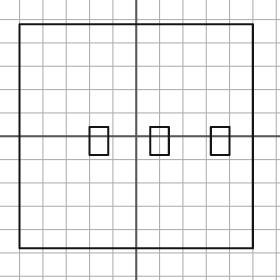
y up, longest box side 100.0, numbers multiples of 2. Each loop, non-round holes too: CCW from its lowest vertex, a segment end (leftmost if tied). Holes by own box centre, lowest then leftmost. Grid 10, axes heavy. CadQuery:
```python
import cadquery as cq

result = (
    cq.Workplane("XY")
    .moveTo(-50.0, -48.0)
    .lineTo(50.0, -48.0)
    .lineTo(50.0, 48.0)
    .lineTo(-50.0, 48.0)
    .close()
    .moveTo(-20.0, -8.0)
    .lineTo(-12.0, -8.0)
    .lineTo(-12.0, 4.0)
    .lineTo(-20.0, 4.0)
    .close()
    .moveTo(6.0, -8.0)
    .lineTo(14.0, -8.0)
    .lineTo(14.0, 4.0)
    .lineTo(6.0, 4.0)
    .close()
    .moveTo(32.0, -8.0)
    .lineTo(40.0, -8.0)
    .lineTo(40.0, 4.0)
    .lineTo(32.0, 4.0)
    .close()
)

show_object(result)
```